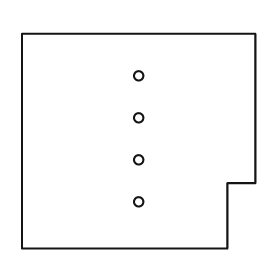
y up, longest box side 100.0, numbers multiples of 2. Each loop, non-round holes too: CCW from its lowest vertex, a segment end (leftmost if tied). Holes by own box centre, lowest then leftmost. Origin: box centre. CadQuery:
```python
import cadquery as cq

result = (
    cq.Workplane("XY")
    .moveTo(-50.0, -46.0)
    .lineTo(38.0, -46.0)
    .lineTo(38.0, -18.0)
    .lineTo(50.0, -18.0)
    .lineTo(50.0, 46.0)
    .lineTo(-50.0, 46.0)
    .close()
    .moveTo(0.0, -26.0)
    .circle(2.0)
    .moveTo(0.0, -8.0)
    .circle(2.0)
    .moveTo(0.0, 10.0)
    .circle(2.0)
    .moveTo(0.0, 28.0)
    .circle(2.0)
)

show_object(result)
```